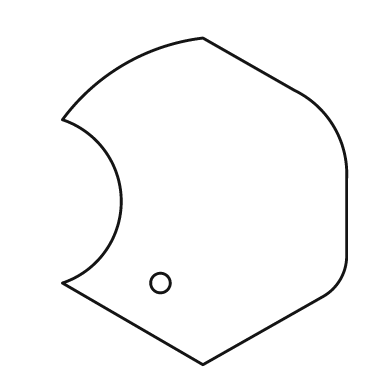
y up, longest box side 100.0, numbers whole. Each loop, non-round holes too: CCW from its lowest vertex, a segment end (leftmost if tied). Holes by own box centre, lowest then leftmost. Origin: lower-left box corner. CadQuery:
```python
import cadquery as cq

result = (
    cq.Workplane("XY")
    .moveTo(43.0, 0.0)
    .lineTo(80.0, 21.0)
    .threePointArc((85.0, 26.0), (87.0, 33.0))
    .lineTo(87.0, 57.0)
    .threePointArc((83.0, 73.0), (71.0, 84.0))
    .lineTo(43.0, 100.0)
    .threePointArc((19.0, 92.0), (0.0, 75.0))
    .threePointArc((18.0, 50.0), (0.0, 25.0))
    .close()
    .moveTo(30.0, 25.0)
    .circle(3.0)
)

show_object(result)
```